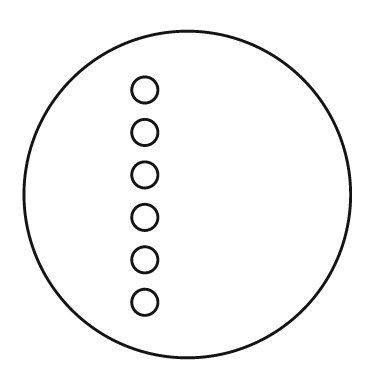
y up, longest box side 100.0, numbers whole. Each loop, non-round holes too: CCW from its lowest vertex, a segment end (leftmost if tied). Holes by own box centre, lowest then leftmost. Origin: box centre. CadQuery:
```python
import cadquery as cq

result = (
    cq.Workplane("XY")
    .moveTo(0.0, 0.0)
    .circle(50.0)
    .moveTo(-13.0, -33.0)
    .circle(4.0)
    .moveTo(-13.0, -20.0)
    .circle(4.0)
    .moveTo(-13.0, -7.0)
    .circle(4.0)
    .moveTo(-13.0, 6.0)
    .circle(4.0)
    .moveTo(-13.0, 19.0)
    .circle(4.0)
    .moveTo(-13.0, 32.0)
    .circle(4.0)
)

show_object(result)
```